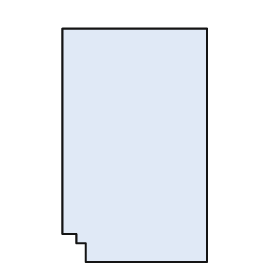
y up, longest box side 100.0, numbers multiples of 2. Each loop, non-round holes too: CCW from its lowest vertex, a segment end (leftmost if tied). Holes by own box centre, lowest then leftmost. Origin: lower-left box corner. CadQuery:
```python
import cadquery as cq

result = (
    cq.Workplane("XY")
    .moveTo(10.0, 0.0)
    .lineTo(62.0, 0.0)
    .lineTo(62.0, 100.0)
    .lineTo(0.0, 100.0)
    .lineTo(0.0, 12.0)
    .lineTo(6.0, 12.0)
    .lineTo(6.0, 8.0)
    .lineTo(10.0, 8.0)
    .close()
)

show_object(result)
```